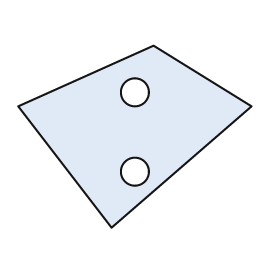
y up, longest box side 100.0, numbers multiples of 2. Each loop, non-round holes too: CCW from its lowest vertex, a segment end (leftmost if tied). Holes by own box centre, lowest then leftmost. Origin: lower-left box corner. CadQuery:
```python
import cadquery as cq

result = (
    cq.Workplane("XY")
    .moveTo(40.0, 0.0)
    .lineTo(100.0, 52.0)
    .lineTo(58.0, 78.0)
    .lineTo(0.0, 52.0)
    .close()
    .moveTo(50.0, 24.0)
    .circle(6.0)
    .moveTo(50.0, 58.0)
    .circle(6.0)
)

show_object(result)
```